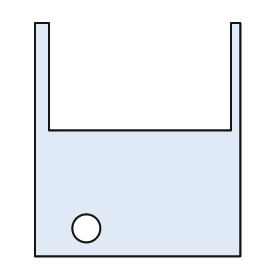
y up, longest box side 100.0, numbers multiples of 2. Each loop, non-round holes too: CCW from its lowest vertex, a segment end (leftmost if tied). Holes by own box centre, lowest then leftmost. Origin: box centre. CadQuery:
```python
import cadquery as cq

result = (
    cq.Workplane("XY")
    .moveTo(-44.0, -50.0)
    .lineTo(44.0, -50.0)
    .lineTo(44.0, 50.0)
    .lineTo(40.0, 50.0)
    .lineTo(40.0, 4.0)
    .lineTo(-38.0, 4.0)
    .lineTo(-38.0, 50.0)
    .lineTo(-44.0, 50.0)
    .close()
    .moveTo(-22.0, -38.0)
    .circle(6.0)
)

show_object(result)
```